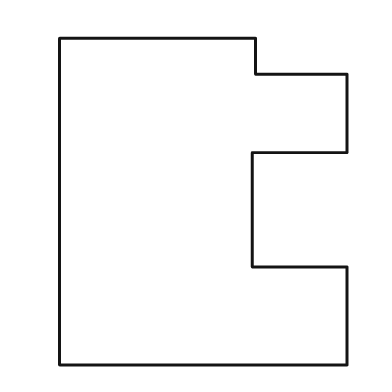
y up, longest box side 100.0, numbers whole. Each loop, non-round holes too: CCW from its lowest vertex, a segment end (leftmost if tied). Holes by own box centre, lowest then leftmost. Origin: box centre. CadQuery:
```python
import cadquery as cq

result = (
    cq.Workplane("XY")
    .moveTo(-44.0, -50.0)
    .lineTo(44.0, -50.0)
    .lineTo(44.0, -20.0)
    .lineTo(15.0, -20.0)
    .lineTo(15.0, 15.0)
    .lineTo(44.0, 15.0)
    .lineTo(44.0, 39.0)
    .lineTo(16.0, 39.0)
    .lineTo(16.0, 50.0)
    .lineTo(-44.0, 50.0)
    .close()
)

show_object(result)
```